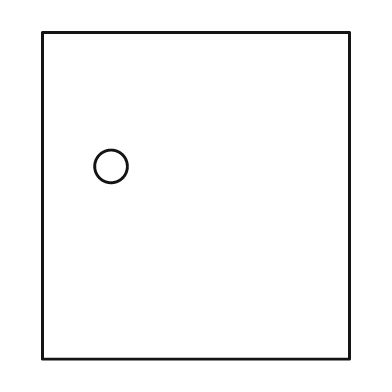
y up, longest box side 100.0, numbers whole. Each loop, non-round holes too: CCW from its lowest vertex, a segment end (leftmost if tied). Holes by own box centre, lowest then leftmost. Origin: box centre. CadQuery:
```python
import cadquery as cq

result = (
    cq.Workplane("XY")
    .moveTo(-47.0, -50.0)
    .lineTo(47.0, -50.0)
    .lineTo(47.0, 50.0)
    .lineTo(-47.0, 50.0)
    .close()
    .moveTo(-26.0, 9.0)
    .circle(5.0)
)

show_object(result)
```